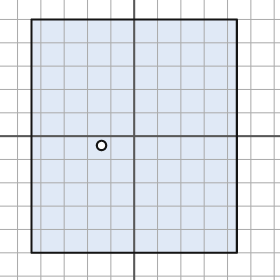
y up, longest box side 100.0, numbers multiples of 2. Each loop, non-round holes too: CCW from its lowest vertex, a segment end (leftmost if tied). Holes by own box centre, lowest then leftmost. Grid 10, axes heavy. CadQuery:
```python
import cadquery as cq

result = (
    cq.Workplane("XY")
    .moveTo(-44.0, -50.0)
    .lineTo(44.0, -50.0)
    .lineTo(44.0, 50.0)
    .lineTo(-44.0, 50.0)
    .close()
    .moveTo(-14.0, -4.0)
    .circle(2.0)
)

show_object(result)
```